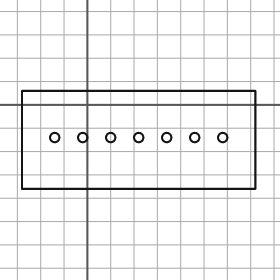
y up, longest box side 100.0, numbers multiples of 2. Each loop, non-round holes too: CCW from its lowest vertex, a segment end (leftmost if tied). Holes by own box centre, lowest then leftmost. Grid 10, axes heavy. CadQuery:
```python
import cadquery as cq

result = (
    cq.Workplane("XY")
    .moveTo(-28.0, -36.0)
    .lineTo(72.0, -36.0)
    .lineTo(72.0, 6.0)
    .lineTo(-28.0, 6.0)
    .close()
    .moveTo(-14.0, -14.0)
    .circle(2.0)
    .moveTo(-2.0, -14.0)
    .circle(2.0)
    .moveTo(10.0, -14.0)
    .circle(2.0)
    .moveTo(22.0, -14.0)
    .circle(2.0)
    .moveTo(34.0, -14.0)
    .circle(2.0)
    .moveTo(46.0, -14.0)
    .circle(2.0)
    .moveTo(58.0, -14.0)
    .circle(2.0)
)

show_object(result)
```